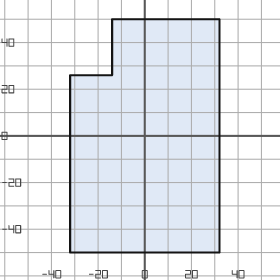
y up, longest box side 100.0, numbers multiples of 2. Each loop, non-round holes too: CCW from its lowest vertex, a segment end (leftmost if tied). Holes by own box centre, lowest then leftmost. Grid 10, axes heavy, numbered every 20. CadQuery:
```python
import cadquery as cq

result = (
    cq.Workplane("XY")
    .moveTo(-32.0, -50.0)
    .lineTo(32.0, -50.0)
    .lineTo(32.0, 50.0)
    .lineTo(-14.0, 50.0)
    .lineTo(-14.0, 26.0)
    .lineTo(-32.0, 26.0)
    .close()
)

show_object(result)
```